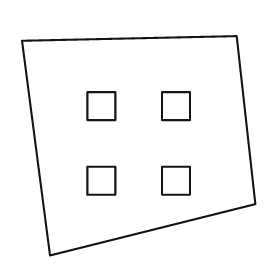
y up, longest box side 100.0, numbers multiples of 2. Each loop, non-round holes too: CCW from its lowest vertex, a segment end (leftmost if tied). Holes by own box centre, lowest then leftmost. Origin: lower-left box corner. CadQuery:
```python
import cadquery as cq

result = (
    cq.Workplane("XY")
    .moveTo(12.0, 0.0)
    .lineTo(100.0, 22.0)
    .lineTo(92.0, 94.0)
    .lineTo(0.0, 92.0)
    .close()
    .moveTo(28.0, 26.0)
    .lineTo(40.0, 26.0)
    .lineTo(40.0, 38.0)
    .lineTo(28.0, 38.0)
    .close()
    .moveTo(60.0, 26.0)
    .lineTo(72.0, 26.0)
    .lineTo(72.0, 38.0)
    .lineTo(60.0, 38.0)
    .close()
    .moveTo(28.0, 58.0)
    .lineTo(40.0, 58.0)
    .lineTo(40.0, 70.0)
    .lineTo(28.0, 70.0)
    .close()
    .moveTo(60.0, 58.0)
    .lineTo(72.0, 58.0)
    .lineTo(72.0, 70.0)
    .lineTo(60.0, 70.0)
    .close()
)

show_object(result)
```